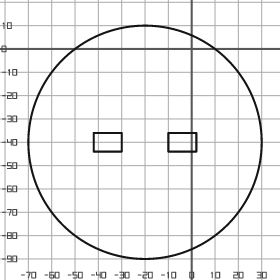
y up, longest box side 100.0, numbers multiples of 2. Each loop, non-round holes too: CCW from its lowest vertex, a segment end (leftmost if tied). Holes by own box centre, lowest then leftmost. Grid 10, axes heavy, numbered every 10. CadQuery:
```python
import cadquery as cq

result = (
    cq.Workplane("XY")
    .moveTo(-20.0, -40.0)
    .circle(50.0)
    .moveTo(-42.0, -44.0)
    .lineTo(-30.0, -44.0)
    .lineTo(-30.0, -36.0)
    .lineTo(-42.0, -36.0)
    .close()
    .moveTo(-10.0, -44.0)
    .lineTo(2.0, -44.0)
    .lineTo(2.0, -36.0)
    .lineTo(-10.0, -36.0)
    .close()
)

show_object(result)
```